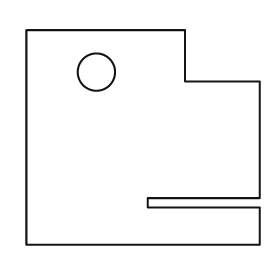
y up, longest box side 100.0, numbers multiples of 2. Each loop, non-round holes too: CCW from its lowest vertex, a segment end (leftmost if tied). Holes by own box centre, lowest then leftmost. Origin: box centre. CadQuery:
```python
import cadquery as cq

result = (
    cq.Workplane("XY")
    .moveTo(-50.0, -46.0)
    .lineTo(50.0, -46.0)
    .lineTo(50.0, -30.0)
    .lineTo(2.0, -30.0)
    .lineTo(2.0, -26.0)
    .lineTo(50.0, -26.0)
    .lineTo(50.0, 24.0)
    .lineTo(18.0, 24.0)
    .lineTo(18.0, 46.0)
    .lineTo(-50.0, 46.0)
    .close()
    .moveTo(-20.0, 28.0)
    .circle(8.0)
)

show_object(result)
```